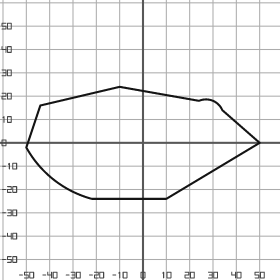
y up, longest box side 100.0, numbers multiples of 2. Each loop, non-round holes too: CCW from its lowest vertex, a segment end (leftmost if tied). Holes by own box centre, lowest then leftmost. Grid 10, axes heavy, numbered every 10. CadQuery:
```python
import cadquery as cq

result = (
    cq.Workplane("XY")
    .moveTo(-22.0, -24.0)
    .lineTo(10.0, -24.0)
    .lineTo(50.0, 0.0)
    .lineTo(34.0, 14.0)
    .threePointArc((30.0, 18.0), (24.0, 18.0))
    .lineTo(-10.0, 24.0)
    .lineTo(-44.0, 16.0)
    .lineTo(-50.0, -2.0)
    .threePointArc((-38.0, -16.0), (-22.0, -24.0))
    .close()
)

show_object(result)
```